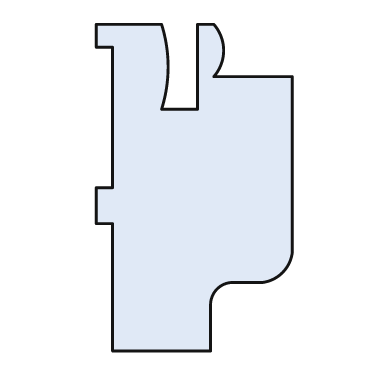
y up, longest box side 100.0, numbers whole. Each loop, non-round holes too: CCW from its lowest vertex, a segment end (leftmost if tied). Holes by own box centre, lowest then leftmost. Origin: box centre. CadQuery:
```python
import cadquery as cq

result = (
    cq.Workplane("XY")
    .moveTo(-25.0, -50.0)
    .lineTo(5.0, -50.0)
    .lineTo(5.0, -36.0)
    .threePointArc((7.0, -31.0), (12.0, -29.0))
    .lineTo(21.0, -29.0)
    .threePointArc((27.0, -26.0), (30.0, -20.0))
    .lineTo(30.0, 34.0)
    .lineTo(6.0, 34.0)
    .threePointArc((9.0, 42.0), (6.0, 50.0))
    .lineTo(1.0, 50.0)
    .lineTo(1.0, 24.0)
    .lineTo(-10.0, 24.0)
    .threePointArc((-8.0, 37.0), (-10.0, 50.0))
    .lineTo(-30.0, 50.0)
    .lineTo(-30.0, 43.0)
    .lineTo(-25.0, 43.0)
    .lineTo(-25.0, 0.0)
    .lineTo(-30.0, 0.0)
    .lineTo(-30.0, -11.0)
    .lineTo(-25.0, -11.0)
    .close()
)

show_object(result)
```